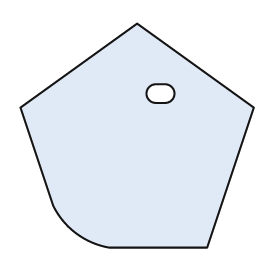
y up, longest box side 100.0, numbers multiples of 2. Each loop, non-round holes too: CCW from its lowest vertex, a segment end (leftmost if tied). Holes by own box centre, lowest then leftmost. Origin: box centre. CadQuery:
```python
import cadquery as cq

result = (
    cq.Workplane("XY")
    .moveTo(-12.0, -48.0)
    .lineTo(30.0, -48.0)
    .lineTo(50.0, 12.0)
    .lineTo(0.0, 48.0)
    .lineTo(-50.0, 12.0)
    .lineTo(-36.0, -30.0)
    .threePointArc((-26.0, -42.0), (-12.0, -48.0))
    .close()
    .moveTo(8.0, 14.0)
    .lineTo(12.0, 14.0)
    .threePointArc((16.0, 18.0), (12.0, 22.0))
    .lineTo(8.0, 22.0)
    .threePointArc((4.0, 18.0), (8.0, 14.0))
    .close()
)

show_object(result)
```